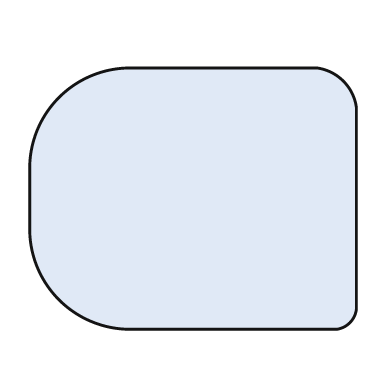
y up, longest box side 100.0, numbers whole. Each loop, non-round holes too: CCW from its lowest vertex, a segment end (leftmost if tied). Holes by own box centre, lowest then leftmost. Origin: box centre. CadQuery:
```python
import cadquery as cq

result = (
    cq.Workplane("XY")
    .moveTo(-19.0, -40.0)
    .lineTo(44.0, -40.0)
    .threePointArc((48.0, -38.0), (50.0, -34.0))
    .lineTo(50.0, 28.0)
    .threePointArc((46.0, 36.0), (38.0, 40.0))
    .lineTo(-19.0, 40.0)
    .threePointArc((-41.0, 31.0), (-50.0, 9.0))
    .lineTo(-50.0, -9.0)
    .threePointArc((-41.0, -31.0), (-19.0, -40.0))
    .close()
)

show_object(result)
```